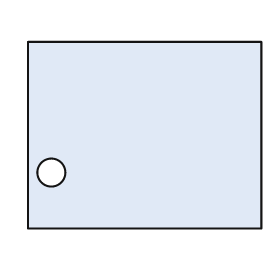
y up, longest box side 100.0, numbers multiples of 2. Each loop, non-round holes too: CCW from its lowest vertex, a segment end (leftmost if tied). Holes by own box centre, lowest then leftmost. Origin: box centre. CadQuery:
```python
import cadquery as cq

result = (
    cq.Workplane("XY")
    .moveTo(-50.0, -40.0)
    .lineTo(50.0, -40.0)
    .lineTo(50.0, 40.0)
    .lineTo(-50.0, 40.0)
    .close()
    .moveTo(-40.0, -16.0)
    .circle(6.0)
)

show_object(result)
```